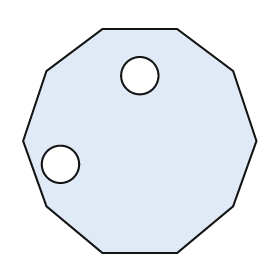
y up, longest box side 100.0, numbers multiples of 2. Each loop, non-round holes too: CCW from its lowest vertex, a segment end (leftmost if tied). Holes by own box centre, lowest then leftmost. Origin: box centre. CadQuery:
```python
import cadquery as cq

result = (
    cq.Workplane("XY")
    .moveTo(-16.0, -48.0)
    .lineTo(16.0, -48.0)
    .lineTo(40.0, -28.0)
    .lineTo(50.0, 0.0)
    .lineTo(40.0, 30.0)
    .lineTo(16.0, 48.0)
    .lineTo(-16.0, 48.0)
    .lineTo(-40.0, 30.0)
    .lineTo(-50.0, 0.0)
    .lineTo(-40.0, -28.0)
    .close()
    .moveTo(-34.0, -10.0)
    .circle(8.0)
    .moveTo(0.0, 28.0)
    .circle(8.0)
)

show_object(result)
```